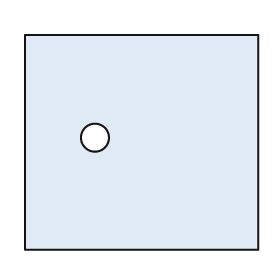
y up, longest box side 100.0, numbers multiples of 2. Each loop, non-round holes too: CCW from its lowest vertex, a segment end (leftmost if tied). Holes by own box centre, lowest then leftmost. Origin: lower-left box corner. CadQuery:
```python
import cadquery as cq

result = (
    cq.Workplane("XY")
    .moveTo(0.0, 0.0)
    .lineTo(100.0, 0.0)
    .lineTo(100.0, 92.0)
    .lineTo(0.0, 92.0)
    .close()
    .moveTo(30.0, 48.0)
    .circle(6.0)
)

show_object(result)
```